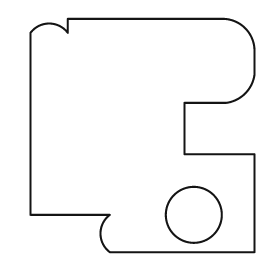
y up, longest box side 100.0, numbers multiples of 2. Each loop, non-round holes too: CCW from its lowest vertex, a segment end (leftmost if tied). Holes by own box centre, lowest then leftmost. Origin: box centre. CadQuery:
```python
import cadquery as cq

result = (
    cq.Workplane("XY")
    .moveTo(-14.0, -50.0)
    .lineTo(48.0, -50.0)
    .lineTo(48.0, -8.0)
    .lineTo(18.0, -8.0)
    .lineTo(18.0, 14.0)
    .lineTo(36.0, 14.0)
    .threePointArc((44.0, 18.0), (48.0, 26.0))
    .lineTo(48.0, 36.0)
    .threePointArc((44.0, 46.0), (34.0, 50.0))
    .lineTo(-32.0, 50.0)
    .lineTo(-32.0, 44.0)
    .threePointArc((-40.0, 48.0), (-48.0, 44.0))
    .lineTo(-48.0, -34.0)
    .lineTo(-14.0, -34.0)
    .threePointArc((-18.0, -42.0), (-14.0, -50.0))
    .close()
    .moveTo(22.0, -34.0)
    .circle(12.0)
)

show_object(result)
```